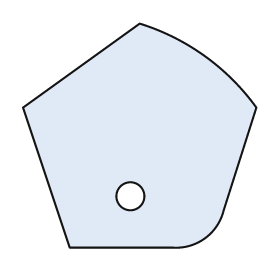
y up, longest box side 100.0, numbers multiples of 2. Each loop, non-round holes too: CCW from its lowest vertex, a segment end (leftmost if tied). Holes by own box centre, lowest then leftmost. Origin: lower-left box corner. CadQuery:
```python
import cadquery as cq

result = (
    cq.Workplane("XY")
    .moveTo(20.0, 0.0)
    .lineTo(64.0, 0.0)
    .threePointArc((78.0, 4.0), (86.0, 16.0))
    .lineTo(100.0, 60.0)
    .threePointArc((78.0, 82.0), (50.0, 96.0))
    .lineTo(0.0, 60.0)
    .close()
    .moveTo(46.0, 22.0)
    .circle(6.0)
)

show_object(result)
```